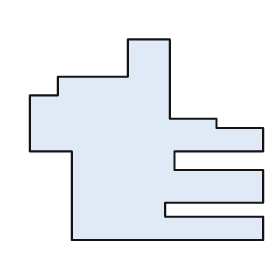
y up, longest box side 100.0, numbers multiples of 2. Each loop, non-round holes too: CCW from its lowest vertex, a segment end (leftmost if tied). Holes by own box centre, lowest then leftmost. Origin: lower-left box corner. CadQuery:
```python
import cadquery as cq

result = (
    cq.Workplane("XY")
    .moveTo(18.0, 0.0)
    .lineTo(100.0, 0.0)
    .lineTo(100.0, 10.0)
    .lineTo(58.0, 10.0)
    .lineTo(58.0, 16.0)
    .lineTo(100.0, 16.0)
    .lineTo(100.0, 30.0)
    .lineTo(62.0, 30.0)
    .lineTo(62.0, 38.0)
    .lineTo(100.0, 38.0)
    .lineTo(100.0, 48.0)
    .lineTo(80.0, 48.0)
    .lineTo(80.0, 52.0)
    .lineTo(60.0, 52.0)
    .lineTo(60.0, 86.0)
    .lineTo(42.0, 86.0)
    .lineTo(42.0, 70.0)
    .lineTo(12.0, 70.0)
    .lineTo(12.0, 62.0)
    .lineTo(0.0, 62.0)
    .lineTo(0.0, 38.0)
    .lineTo(18.0, 38.0)
    .close()
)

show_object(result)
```